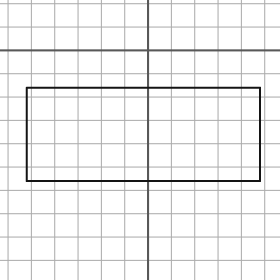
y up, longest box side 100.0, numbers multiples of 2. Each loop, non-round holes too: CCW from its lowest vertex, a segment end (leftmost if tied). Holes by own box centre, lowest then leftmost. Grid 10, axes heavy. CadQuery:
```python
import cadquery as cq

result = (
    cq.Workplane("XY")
    .moveTo(-52.0, -56.0)
    .lineTo(48.0, -56.0)
    .lineTo(48.0, -16.0)
    .lineTo(-52.0, -16.0)
    .close()
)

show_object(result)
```